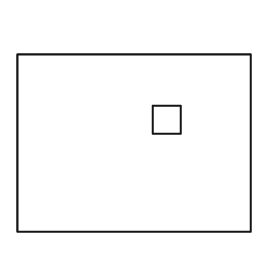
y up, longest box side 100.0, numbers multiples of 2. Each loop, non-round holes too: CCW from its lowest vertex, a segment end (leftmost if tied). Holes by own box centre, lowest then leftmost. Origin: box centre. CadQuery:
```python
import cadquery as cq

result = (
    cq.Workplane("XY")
    .moveTo(-50.0, -38.0)
    .lineTo(50.0, -38.0)
    .lineTo(50.0, 38.0)
    .lineTo(-50.0, 38.0)
    .close()
    .moveTo(8.0, 4.0)
    .lineTo(20.0, 4.0)
    .lineTo(20.0, 16.0)
    .lineTo(8.0, 16.0)
    .close()
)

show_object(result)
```